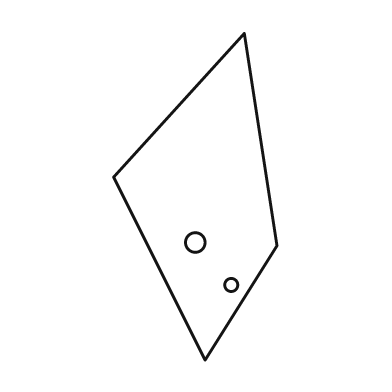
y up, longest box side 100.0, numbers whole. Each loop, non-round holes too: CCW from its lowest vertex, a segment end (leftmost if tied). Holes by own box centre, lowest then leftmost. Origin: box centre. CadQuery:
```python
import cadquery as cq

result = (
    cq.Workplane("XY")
    .moveTo(3.0, -50.0)
    .lineTo(25.0, -15.0)
    .lineTo(15.0, 50.0)
    .lineTo(-25.0, 6.0)
    .close()
    .moveTo(11.0, -27.0)
    .circle(2.0)
    .moveTo(0.0, -14.0)
    .circle(3.0)
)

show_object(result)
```